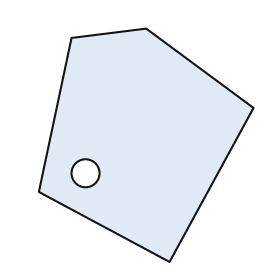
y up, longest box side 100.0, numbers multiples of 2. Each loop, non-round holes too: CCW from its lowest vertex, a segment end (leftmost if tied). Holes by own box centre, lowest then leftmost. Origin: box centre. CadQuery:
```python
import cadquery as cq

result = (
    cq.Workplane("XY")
    .moveTo(10.0, -50.0)
    .lineTo(46.0, 16.0)
    .lineTo(0.0, 50.0)
    .lineTo(-32.0, 46.0)
    .lineTo(-46.0, -20.0)
    .close()
    .moveTo(-26.0, -12.0)
    .circle(6.0)
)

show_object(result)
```